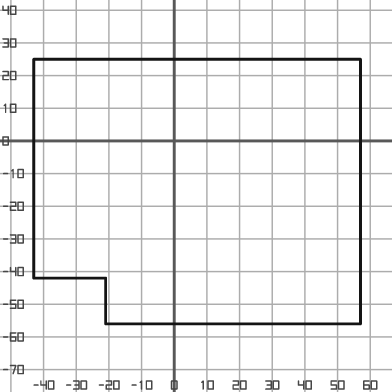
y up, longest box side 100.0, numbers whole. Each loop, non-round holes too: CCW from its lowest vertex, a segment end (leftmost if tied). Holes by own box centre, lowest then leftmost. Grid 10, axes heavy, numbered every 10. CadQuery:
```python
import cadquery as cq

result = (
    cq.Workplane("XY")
    .moveTo(-21.0, -56.0)
    .lineTo(57.0, -56.0)
    .lineTo(57.0, 25.0)
    .lineTo(-43.0, 25.0)
    .lineTo(-43.0, -42.0)
    .lineTo(-21.0, -42.0)
    .close()
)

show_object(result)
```